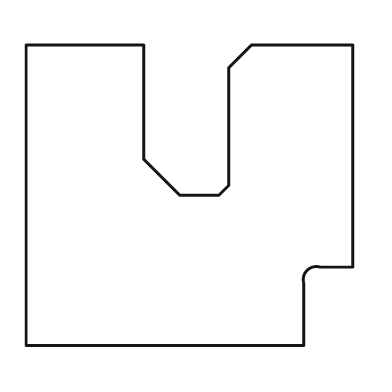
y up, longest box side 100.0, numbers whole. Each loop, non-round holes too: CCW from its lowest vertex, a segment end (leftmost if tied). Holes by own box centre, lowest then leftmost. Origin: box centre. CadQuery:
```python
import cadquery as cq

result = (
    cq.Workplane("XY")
    .moveTo(-50.0, -46.0)
    .lineTo(35.0, -46.0)
    .lineTo(35.0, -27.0)
    .threePointArc((36.0, -23.0), (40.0, -22.0))
    .lineTo(50.0, -22.0)
    .lineTo(50.0, 46.0)
    .lineTo(19.0, 46.0)
    .lineTo(12.0, 39.0)
    .lineTo(12.0, 3.0)
    .lineTo(9.0, 0.0)
    .lineTo(-3.0, 0.0)
    .lineTo(-14.0, 11.0)
    .lineTo(-14.0, 46.0)
    .lineTo(-50.0, 46.0)
    .close()
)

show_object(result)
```